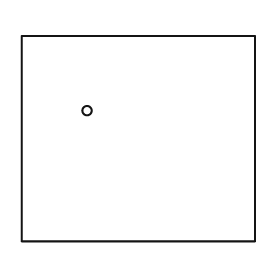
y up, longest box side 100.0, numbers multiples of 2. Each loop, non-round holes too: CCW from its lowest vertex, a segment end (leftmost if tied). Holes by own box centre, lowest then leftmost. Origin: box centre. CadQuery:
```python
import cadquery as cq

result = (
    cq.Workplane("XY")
    .moveTo(-50.0, -44.0)
    .lineTo(50.0, -44.0)
    .lineTo(50.0, 44.0)
    .lineTo(-50.0, 44.0)
    .close()
    .moveTo(-22.0, 12.0)
    .circle(2.0)
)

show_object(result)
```